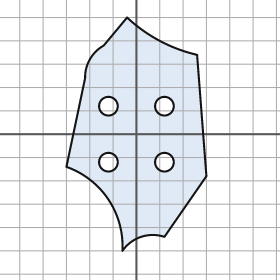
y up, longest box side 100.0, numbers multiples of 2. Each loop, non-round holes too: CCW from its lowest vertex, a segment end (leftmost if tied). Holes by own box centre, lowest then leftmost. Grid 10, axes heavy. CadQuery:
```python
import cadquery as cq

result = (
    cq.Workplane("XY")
    .moveTo(-6.0, -50.0)
    .threePointArc((2.0, -44.0), (12.0, -44.0))
    .lineTo(30.0, -18.0)
    .lineTo(26.0, 34.0)
    .threePointArc((10.0, 40.0), (-4.0, 50.0))
    .lineTo(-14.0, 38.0)
    .threePointArc((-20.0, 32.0), (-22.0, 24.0))
    .lineTo(-30.0, -14.0)
    .threePointArc((-12.0, -28.0), (-6.0, -50.0))
    .close()
    .moveTo(-12.0, -12.0)
    .circle(4.0)
    .moveTo(12.0, -12.0)
    .circle(4.0)
    .moveTo(-12.0, 12.0)
    .circle(4.0)
    .moveTo(12.0, 12.0)
    .circle(4.0)
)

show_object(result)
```